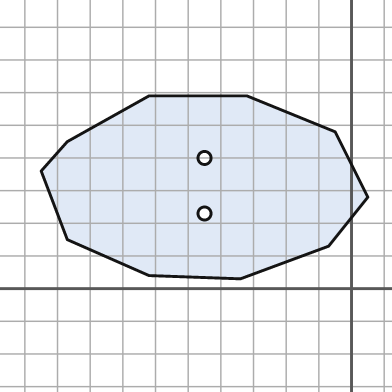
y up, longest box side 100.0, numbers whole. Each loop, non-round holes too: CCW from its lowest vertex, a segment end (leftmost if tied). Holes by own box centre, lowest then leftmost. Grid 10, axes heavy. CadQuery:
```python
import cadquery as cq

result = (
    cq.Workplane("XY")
    .moveTo(-34.0, 3.0)
    .lineTo(-7.0, 13.0)
    .lineTo(5.0, 28.0)
    .lineTo(-5.0, 48.0)
    .lineTo(-32.0, 59.0)
    .lineTo(-62.0, 59.0)
    .lineTo(-87.0, 45.0)
    .lineTo(-95.0, 36.0)
    .lineTo(-87.0, 15.0)
    .lineTo(-62.0, 4.0)
    .close()
    .moveTo(-45.0, 23.0)
    .circle(2.0)
    .moveTo(-45.0, 40.0)
    .circle(2.0)
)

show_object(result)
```